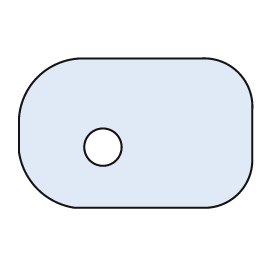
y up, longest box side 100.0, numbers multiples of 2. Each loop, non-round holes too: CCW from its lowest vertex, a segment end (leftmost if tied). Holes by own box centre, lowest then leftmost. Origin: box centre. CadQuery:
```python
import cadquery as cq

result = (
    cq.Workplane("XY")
    .moveTo(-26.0, -32.0)
    .lineTo(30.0, -32.0)
    .threePointArc((44.0, -26.0), (50.0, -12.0))
    .lineTo(50.0, 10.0)
    .threePointArc((44.0, 26.0), (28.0, 32.0))
    .lineTo(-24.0, 32.0)
    .threePointArc((-42.0, 24.0), (-50.0, 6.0))
    .lineTo(-50.0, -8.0)
    .threePointArc((-42.0, -24.0), (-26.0, -32.0))
    .close()
    .moveTo(-14.0, -6.0)
    .circle(8.0)
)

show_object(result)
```